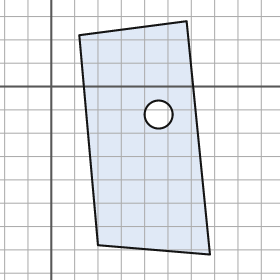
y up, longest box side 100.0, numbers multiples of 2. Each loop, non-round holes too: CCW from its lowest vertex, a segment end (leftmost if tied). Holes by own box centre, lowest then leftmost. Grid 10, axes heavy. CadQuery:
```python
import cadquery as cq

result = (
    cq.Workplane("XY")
    .moveTo(68.0, -72.0)
    .lineTo(58.0, 28.0)
    .lineTo(12.0, 22.0)
    .lineTo(20.0, -68.0)
    .close()
    .moveTo(46.0, -12.0)
    .circle(6.0)
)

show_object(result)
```